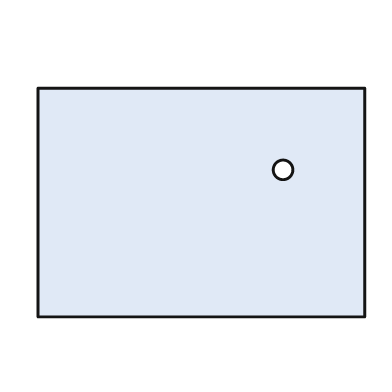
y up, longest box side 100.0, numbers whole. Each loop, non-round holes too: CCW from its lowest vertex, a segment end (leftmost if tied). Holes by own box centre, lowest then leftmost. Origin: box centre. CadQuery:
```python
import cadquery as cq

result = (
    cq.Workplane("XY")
    .moveTo(-50.0, -35.0)
    .lineTo(50.0, -35.0)
    .lineTo(50.0, 35.0)
    .lineTo(-50.0, 35.0)
    .close()
    .moveTo(25.0, 10.0)
    .circle(3.0)
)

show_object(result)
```